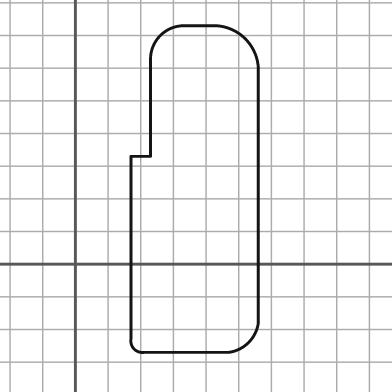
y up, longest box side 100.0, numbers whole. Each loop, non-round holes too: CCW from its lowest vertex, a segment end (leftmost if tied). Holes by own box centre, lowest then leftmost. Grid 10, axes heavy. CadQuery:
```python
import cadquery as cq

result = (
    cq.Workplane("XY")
    .moveTo(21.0, -27.0)
    .lineTo(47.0, -27.0)
    .threePointArc((53.0, -24.0), (56.0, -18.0))
    .lineTo(56.0, 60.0)
    .threePointArc((52.0, 69.0), (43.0, 73.0))
    .lineTo(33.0, 73.0)
    .threePointArc((26.0, 70.0), (23.0, 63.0))
    .lineTo(23.0, 33.0)
    .lineTo(17.0, 33.0)
    .lineTo(17.0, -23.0)
    .threePointArc((18.0, -26.0), (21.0, -27.0))
    .close()
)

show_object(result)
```